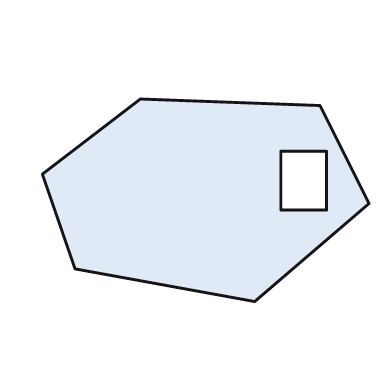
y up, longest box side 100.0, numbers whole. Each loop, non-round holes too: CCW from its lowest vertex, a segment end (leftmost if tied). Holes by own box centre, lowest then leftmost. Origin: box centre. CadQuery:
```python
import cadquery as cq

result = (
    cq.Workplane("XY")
    .moveTo(15.0, -31.0)
    .lineTo(50.0, -1.0)
    .lineTo(35.0, 29.0)
    .lineTo(-20.0, 31.0)
    .lineTo(-50.0, 8.0)
    .lineTo(-40.0, -21.0)
    .close()
    .moveTo(23.0, -3.0)
    .lineTo(37.0, -3.0)
    .lineTo(37.0, 15.0)
    .lineTo(23.0, 15.0)
    .close()
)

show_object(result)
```